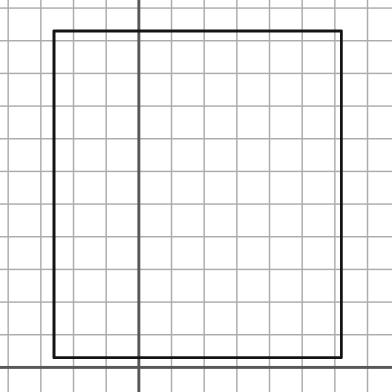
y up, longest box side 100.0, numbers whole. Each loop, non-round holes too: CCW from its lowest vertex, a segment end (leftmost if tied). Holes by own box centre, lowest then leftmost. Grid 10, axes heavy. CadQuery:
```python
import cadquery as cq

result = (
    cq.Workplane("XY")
    .moveTo(-26.0, 3.0)
    .lineTo(62.0, 3.0)
    .lineTo(62.0, 103.0)
    .lineTo(-26.0, 103.0)
    .close()
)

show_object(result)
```